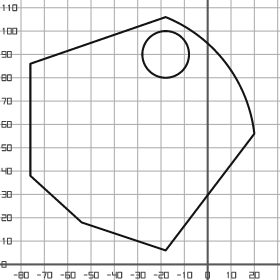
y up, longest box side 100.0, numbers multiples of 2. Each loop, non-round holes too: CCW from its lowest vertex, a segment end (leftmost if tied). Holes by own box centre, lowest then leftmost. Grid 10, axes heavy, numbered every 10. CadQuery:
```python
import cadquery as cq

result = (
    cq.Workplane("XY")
    .moveTo(-18.0, 6.0)
    .lineTo(20.0, 56.0)
    .threePointArc((8.0, 86.0), (-18.0, 106.0))
    .lineTo(-76.0, 86.0)
    .lineTo(-76.0, 38.0)
    .lineTo(-54.0, 18.0)
    .close()
    .moveTo(-18.0, 90.0)
    .circle(10.0)
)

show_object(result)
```